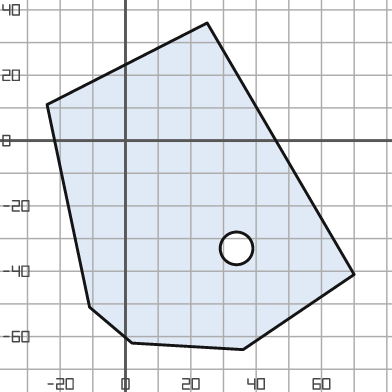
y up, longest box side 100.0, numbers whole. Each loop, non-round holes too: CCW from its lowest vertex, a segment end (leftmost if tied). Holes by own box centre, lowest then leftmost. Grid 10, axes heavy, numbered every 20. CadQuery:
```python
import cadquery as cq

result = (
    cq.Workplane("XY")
    .moveTo(36.0, -64.0)
    .lineTo(70.0, -41.0)
    .lineTo(25.0, 36.0)
    .lineTo(-24.0, 11.0)
    .lineTo(-11.0, -51.0)
    .lineTo(2.0, -62.0)
    .close()
    .moveTo(34.0, -33.0)
    .circle(5.0)
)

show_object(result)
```